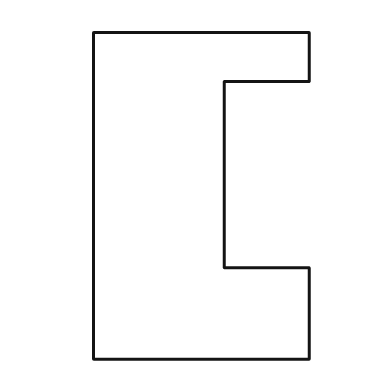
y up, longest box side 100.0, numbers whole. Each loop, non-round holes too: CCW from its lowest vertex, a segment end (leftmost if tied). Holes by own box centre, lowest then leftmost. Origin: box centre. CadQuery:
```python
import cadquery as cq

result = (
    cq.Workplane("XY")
    .moveTo(-33.0, -50.0)
    .lineTo(33.0, -50.0)
    .lineTo(33.0, -22.0)
    .lineTo(7.0, -22.0)
    .lineTo(7.0, 35.0)
    .lineTo(33.0, 35.0)
    .lineTo(33.0, 50.0)
    .lineTo(-33.0, 50.0)
    .close()
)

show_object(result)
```